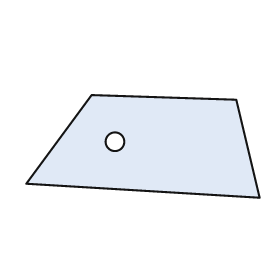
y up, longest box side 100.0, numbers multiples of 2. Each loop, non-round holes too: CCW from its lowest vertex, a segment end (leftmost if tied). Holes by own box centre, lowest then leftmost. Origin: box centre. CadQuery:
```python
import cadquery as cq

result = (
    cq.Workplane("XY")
    .moveTo(50.0, -22.0)
    .lineTo(40.0, 20.0)
    .lineTo(-22.0, 22.0)
    .lineTo(-50.0, -16.0)
    .close()
    .moveTo(-12.0, 2.0)
    .circle(4.0)
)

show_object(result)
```